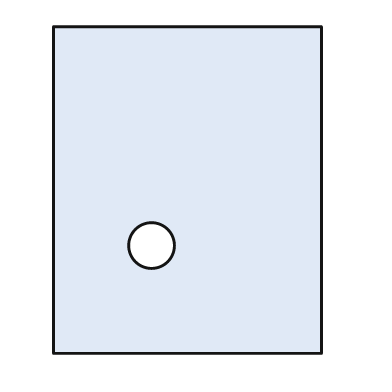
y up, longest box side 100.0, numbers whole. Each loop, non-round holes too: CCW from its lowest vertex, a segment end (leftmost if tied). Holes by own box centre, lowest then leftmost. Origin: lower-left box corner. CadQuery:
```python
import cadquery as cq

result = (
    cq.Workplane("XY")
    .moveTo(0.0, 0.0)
    .lineTo(82.0, 0.0)
    .lineTo(82.0, 100.0)
    .lineTo(0.0, 100.0)
    .close()
    .moveTo(30.0, 33.0)
    .circle(7.0)
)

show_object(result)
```